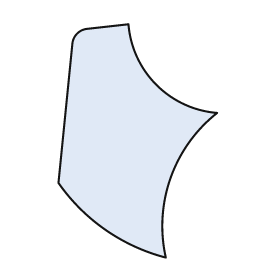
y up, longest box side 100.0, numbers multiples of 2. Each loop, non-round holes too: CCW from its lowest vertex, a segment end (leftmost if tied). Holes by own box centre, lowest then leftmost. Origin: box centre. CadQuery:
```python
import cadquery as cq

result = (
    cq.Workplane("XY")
    .moveTo(12.0, -50.0)
    .threePointArc((14.0, -16.0), (34.0, 12.0))
    .threePointArc((8.0, 24.0), (-4.0, 50.0))
    .lineTo(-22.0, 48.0)
    .threePointArc((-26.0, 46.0), (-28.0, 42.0))
    .lineTo(-34.0, -18.0)
    .threePointArc((-14.0, -38.0), (12.0, -50.0))
    .close()
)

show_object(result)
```